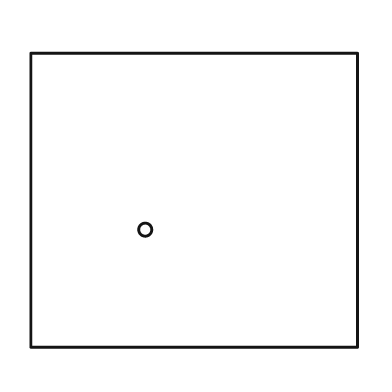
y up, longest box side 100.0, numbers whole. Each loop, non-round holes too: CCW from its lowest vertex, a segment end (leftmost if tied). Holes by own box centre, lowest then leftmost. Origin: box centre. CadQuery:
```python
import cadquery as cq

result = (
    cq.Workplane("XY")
    .moveTo(-50.0, -45.0)
    .lineTo(50.0, -45.0)
    .lineTo(50.0, 45.0)
    .lineTo(-50.0, 45.0)
    .close()
    .moveTo(-15.0, -9.0)
    .circle(2.0)
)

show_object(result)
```